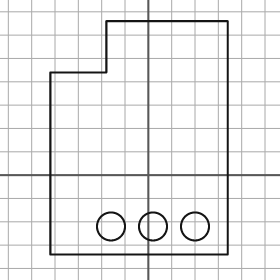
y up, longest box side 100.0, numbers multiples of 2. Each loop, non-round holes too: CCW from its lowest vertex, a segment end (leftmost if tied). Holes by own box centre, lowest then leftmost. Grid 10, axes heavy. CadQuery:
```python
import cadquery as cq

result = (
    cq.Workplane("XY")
    .moveTo(-42.0, -34.0)
    .lineTo(34.0, -34.0)
    .lineTo(34.0, 66.0)
    .lineTo(-18.0, 66.0)
    .lineTo(-18.0, 44.0)
    .lineTo(-42.0, 44.0)
    .close()
    .moveTo(-16.0, -22.0)
    .circle(6.0)
    .moveTo(2.0, -22.0)
    .circle(6.0)
    .moveTo(20.0, -22.0)
    .circle(6.0)
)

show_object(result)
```